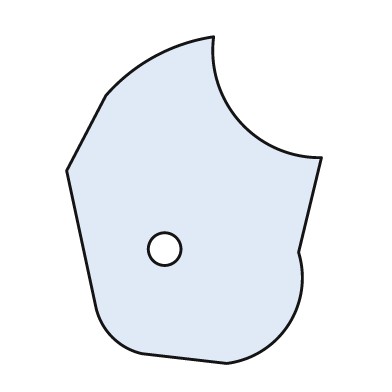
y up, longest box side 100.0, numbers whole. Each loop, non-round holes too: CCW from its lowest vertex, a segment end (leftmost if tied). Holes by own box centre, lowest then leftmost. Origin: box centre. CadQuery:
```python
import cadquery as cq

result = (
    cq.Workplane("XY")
    .moveTo(10.0, -50.0)
    .threePointArc((29.0, -38.0), (32.0, -16.0))
    .lineTo(39.0, 13.0)
    .threePointArc((14.0, 24.0), (6.0, 50.0))
    .threePointArc((-12.0, 44.0), (-27.0, 32.0))
    .lineTo(-39.0, 9.0)
    .lineTo(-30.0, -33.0)
    .threePointArc((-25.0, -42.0), (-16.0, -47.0))
    .close()
    .moveTo(-9.0, -15.0)
    .circle(5.0)
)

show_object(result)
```